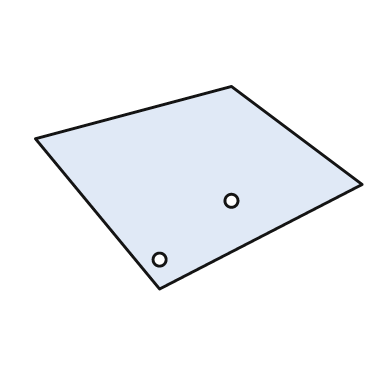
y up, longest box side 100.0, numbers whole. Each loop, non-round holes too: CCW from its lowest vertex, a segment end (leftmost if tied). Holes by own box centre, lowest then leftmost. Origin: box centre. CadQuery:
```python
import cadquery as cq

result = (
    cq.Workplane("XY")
    .moveTo(-12.0, -31.0)
    .lineTo(50.0, 1.0)
    .lineTo(10.0, 31.0)
    .lineTo(-50.0, 15.0)
    .close()
    .moveTo(-12.0, -22.0)
    .circle(2.0)
    .moveTo(10.0, -4.0)
    .circle(2.0)
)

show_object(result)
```